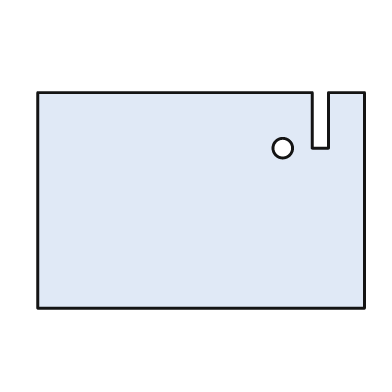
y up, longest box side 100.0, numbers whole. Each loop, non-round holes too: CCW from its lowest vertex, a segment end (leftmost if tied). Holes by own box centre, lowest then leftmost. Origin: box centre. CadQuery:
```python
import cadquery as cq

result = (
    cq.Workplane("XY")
    .moveTo(-50.0, -33.0)
    .lineTo(50.0, -33.0)
    .lineTo(50.0, 33.0)
    .lineTo(39.0, 33.0)
    .lineTo(39.0, 16.0)
    .lineTo(34.0, 16.0)
    .lineTo(34.0, 33.0)
    .lineTo(-50.0, 33.0)
    .close()
    .moveTo(25.0, 16.0)
    .circle(3.0)
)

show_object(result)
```